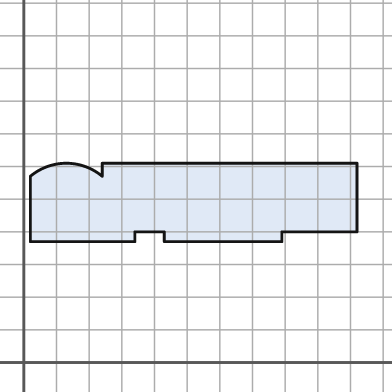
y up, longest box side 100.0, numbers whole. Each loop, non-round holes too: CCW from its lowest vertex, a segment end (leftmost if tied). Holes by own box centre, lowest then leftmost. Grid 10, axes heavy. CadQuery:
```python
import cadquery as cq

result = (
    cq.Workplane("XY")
    .moveTo(2.0, 37.0)
    .lineTo(34.0, 37.0)
    .lineTo(34.0, 40.0)
    .lineTo(43.0, 40.0)
    .lineTo(43.0, 37.0)
    .lineTo(79.0, 37.0)
    .lineTo(79.0, 40.0)
    .lineTo(102.0, 40.0)
    .lineTo(102.0, 61.0)
    .lineTo(24.0, 61.0)
    .lineTo(24.0, 57.0)
    .threePointArc((13.0, 61.0), (2.0, 57.0))
    .close()
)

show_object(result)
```